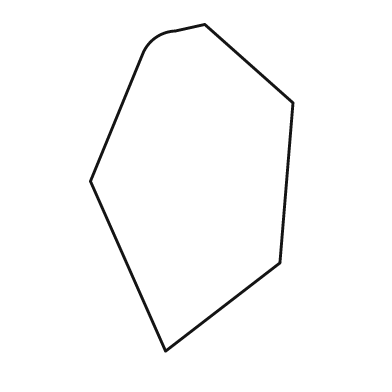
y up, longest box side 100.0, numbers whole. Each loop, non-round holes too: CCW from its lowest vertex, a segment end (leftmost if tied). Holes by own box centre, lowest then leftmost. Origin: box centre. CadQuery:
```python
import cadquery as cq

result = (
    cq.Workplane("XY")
    .moveTo(-8.0, -50.0)
    .lineTo(27.0, -23.0)
    .lineTo(31.0, 26.0)
    .lineTo(4.0, 50.0)
    .lineTo(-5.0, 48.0)
    .threePointArc((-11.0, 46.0), (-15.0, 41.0))
    .lineTo(-31.0, 2.0)
    .close()
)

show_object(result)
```